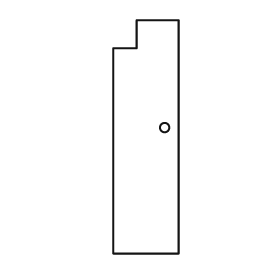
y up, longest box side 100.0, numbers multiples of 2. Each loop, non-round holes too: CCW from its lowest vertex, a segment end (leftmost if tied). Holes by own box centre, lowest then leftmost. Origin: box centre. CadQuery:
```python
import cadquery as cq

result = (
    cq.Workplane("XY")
    .moveTo(-14.0, -50.0)
    .lineTo(14.0, -50.0)
    .lineTo(14.0, 50.0)
    .lineTo(-4.0, 50.0)
    .lineTo(-4.0, 38.0)
    .lineTo(-14.0, 38.0)
    .close()
    .moveTo(8.0, 4.0)
    .circle(2.0)
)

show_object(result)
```